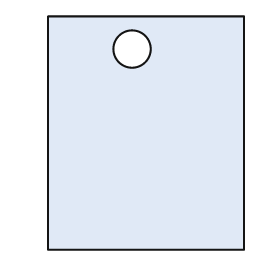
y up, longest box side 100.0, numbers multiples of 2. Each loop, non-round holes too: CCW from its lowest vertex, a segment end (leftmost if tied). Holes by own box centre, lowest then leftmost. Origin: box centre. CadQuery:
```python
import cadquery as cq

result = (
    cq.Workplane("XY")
    .moveTo(-42.0, -50.0)
    .lineTo(42.0, -50.0)
    .lineTo(42.0, 50.0)
    .lineTo(-42.0, 50.0)
    .close()
    .moveTo(-6.0, 36.0)
    .circle(8.0)
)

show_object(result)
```